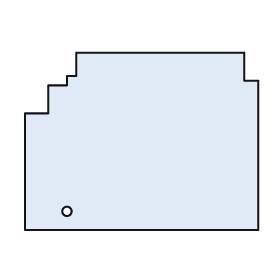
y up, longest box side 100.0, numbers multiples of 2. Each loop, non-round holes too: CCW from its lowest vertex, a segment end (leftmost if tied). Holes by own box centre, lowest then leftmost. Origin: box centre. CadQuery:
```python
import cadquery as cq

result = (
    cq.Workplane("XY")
    .moveTo(-50.0, -38.0)
    .lineTo(50.0, -38.0)
    .lineTo(50.0, 26.0)
    .lineTo(44.0, 26.0)
    .lineTo(44.0, 38.0)
    .lineTo(-28.0, 38.0)
    .lineTo(-28.0, 28.0)
    .lineTo(-32.0, 28.0)
    .lineTo(-32.0, 24.0)
    .lineTo(-40.0, 24.0)
    .lineTo(-40.0, 12.0)
    .lineTo(-50.0, 12.0)
    .close()
    .moveTo(-32.0, -30.0)
    .circle(2.0)
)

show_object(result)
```